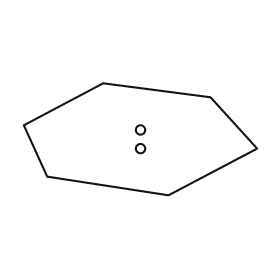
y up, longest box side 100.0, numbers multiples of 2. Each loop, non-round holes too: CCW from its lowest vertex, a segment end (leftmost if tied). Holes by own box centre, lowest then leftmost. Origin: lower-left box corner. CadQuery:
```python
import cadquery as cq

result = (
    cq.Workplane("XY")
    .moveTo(62.0, 0.0)
    .lineTo(100.0, 20.0)
    .lineTo(80.0, 42.0)
    .lineTo(34.0, 48.0)
    .lineTo(0.0, 30.0)
    .lineTo(10.0, 8.0)
    .close()
    .moveTo(50.0, 20.0)
    .circle(2.0)
    .moveTo(50.0, 28.0)
    .circle(2.0)
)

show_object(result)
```